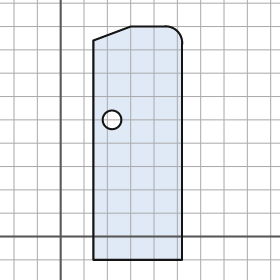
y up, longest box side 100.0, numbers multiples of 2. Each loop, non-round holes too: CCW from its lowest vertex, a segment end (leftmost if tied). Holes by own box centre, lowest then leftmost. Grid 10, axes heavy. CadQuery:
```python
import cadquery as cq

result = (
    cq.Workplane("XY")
    .moveTo(14.0, -10.0)
    .lineTo(52.0, -10.0)
    .lineTo(52.0, 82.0)
    .threePointArc((50.0, 88.0), (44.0, 90.0))
    .lineTo(30.0, 90.0)
    .lineTo(14.0, 84.0)
    .close()
    .moveTo(22.0, 50.0)
    .circle(4.0)
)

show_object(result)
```